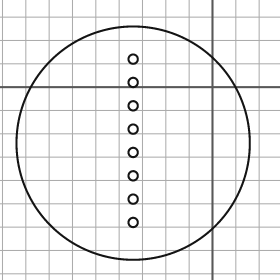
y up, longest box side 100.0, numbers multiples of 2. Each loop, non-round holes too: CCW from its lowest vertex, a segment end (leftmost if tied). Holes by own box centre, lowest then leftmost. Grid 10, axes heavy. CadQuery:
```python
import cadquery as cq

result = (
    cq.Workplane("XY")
    .moveTo(-34.0, -24.0)
    .circle(50.0)
    .moveTo(-34.0, -58.0)
    .circle(2.0)
    .moveTo(-34.0, -48.0)
    .circle(2.0)
    .moveTo(-34.0, -38.0)
    .circle(2.0)
    .moveTo(-34.0, -28.0)
    .circle(2.0)
    .moveTo(-34.0, -18.0)
    .circle(2.0)
    .moveTo(-34.0, -8.0)
    .circle(2.0)
    .moveTo(-34.0, 2.0)
    .circle(2.0)
    .moveTo(-34.0, 12.0)
    .circle(2.0)
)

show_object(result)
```